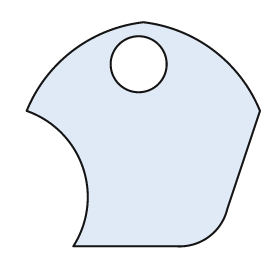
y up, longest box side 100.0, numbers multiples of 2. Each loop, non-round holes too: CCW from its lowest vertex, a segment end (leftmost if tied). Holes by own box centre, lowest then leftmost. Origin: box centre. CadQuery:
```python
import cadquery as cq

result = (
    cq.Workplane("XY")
    .moveTo(-30.0, -48.0)
    .lineTo(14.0, -48.0)
    .threePointArc((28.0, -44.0), (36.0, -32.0))
    .lineTo(50.0, 10.0)
    .threePointArc((30.0, 36.0), (0.0, 48.0))
    .threePointArc((-30.0, 36.0), (-50.0, 10.0))
    .threePointArc((-26.0, -14.0), (-30.0, -48.0))
    .close()
    .moveTo(-2.0, 30.0)
    .circle(12.0)
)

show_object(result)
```